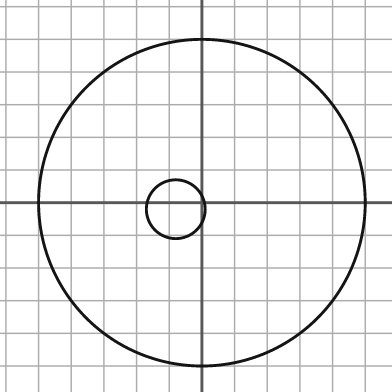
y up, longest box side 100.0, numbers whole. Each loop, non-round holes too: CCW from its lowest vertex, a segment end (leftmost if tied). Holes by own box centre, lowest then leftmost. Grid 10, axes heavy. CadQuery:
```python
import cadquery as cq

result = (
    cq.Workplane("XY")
    .moveTo(0.0, 0.0)
    .circle(50.0)
    .moveTo(-8.0, -2.0)
    .circle(9.0)
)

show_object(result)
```